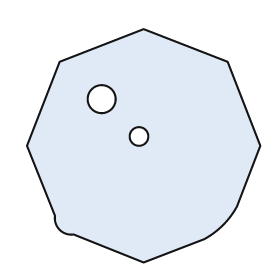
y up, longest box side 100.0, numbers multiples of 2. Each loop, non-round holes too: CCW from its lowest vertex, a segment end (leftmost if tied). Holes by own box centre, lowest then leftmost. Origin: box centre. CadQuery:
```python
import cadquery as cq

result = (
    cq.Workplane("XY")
    .moveTo(0.0, -50.0)
    .lineTo(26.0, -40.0)
    .threePointArc((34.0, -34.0), (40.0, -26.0))
    .lineTo(50.0, 0.0)
    .lineTo(36.0, 36.0)
    .lineTo(0.0, 50.0)
    .lineTo(-36.0, 36.0)
    .lineTo(-50.0, 0.0)
    .lineTo(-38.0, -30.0)
    .threePointArc((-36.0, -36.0), (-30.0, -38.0))
    .close()
    .moveTo(-2.0, 4.0)
    .circle(4.0)
    .moveTo(-18.0, 20.0)
    .circle(6.0)
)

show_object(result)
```